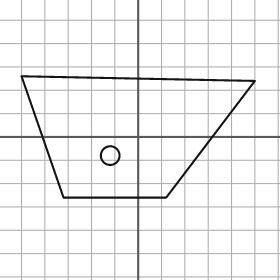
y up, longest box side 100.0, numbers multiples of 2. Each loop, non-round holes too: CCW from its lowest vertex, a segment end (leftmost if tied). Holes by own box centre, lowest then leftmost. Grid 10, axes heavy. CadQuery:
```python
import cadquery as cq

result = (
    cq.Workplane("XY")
    .moveTo(-32.0, -26.0)
    .lineTo(12.0, -26.0)
    .lineTo(50.0, 24.0)
    .lineTo(-50.0, 26.0)
    .close()
    .moveTo(-12.0, -8.0)
    .circle(4.0)
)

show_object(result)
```